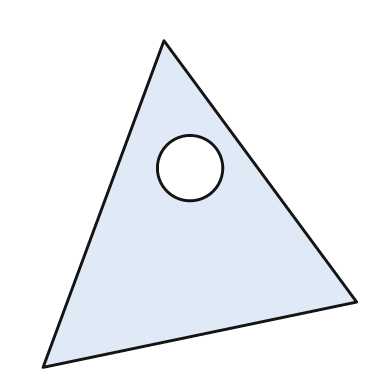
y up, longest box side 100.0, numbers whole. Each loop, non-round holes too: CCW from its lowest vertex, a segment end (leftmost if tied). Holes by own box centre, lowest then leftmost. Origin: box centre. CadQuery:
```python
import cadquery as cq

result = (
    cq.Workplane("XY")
    .moveTo(-48.0, -50.0)
    .lineTo(48.0, -30.0)
    .lineTo(-11.0, 50.0)
    .close()
    .moveTo(-3.0, 11.0)
    .circle(10.0)
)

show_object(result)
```